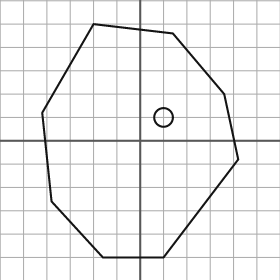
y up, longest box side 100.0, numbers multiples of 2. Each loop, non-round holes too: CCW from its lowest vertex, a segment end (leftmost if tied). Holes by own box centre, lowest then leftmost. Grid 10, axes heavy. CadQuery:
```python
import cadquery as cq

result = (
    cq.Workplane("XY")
    .moveTo(-16.0, -50.0)
    .lineTo(10.0, -50.0)
    .lineTo(42.0, -8.0)
    .lineTo(36.0, 20.0)
    .lineTo(14.0, 46.0)
    .lineTo(-20.0, 50.0)
    .lineTo(-42.0, 12.0)
    .lineTo(-38.0, -26.0)
    .close()
    .moveTo(10.0, 10.0)
    .circle(4.0)
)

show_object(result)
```